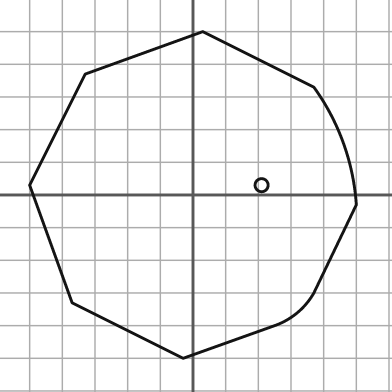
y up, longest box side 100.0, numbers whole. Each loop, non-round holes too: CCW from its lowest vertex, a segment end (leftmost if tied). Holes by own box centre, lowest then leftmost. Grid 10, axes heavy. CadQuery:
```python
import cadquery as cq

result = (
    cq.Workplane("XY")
    .moveTo(-3.0, -50.0)
    .lineTo(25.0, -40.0)
    .threePointArc((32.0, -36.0), (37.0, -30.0))
    .lineTo(50.0, -3.0)
    .threePointArc((46.0, 16.0), (37.0, 33.0))
    .lineTo(3.0, 50.0)
    .lineTo(-33.0, 37.0)
    .lineTo(-50.0, 3.0)
    .lineTo(-37.0, -33.0)
    .close()
    .moveTo(21.0, 3.0)
    .circle(2.0)
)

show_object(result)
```